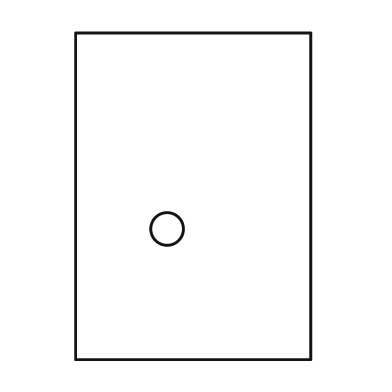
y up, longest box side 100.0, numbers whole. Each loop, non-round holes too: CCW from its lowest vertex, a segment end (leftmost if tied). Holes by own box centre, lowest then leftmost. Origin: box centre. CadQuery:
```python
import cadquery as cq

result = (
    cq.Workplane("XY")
    .moveTo(-36.0, -50.0)
    .lineTo(36.0, -50.0)
    .lineTo(36.0, 50.0)
    .lineTo(-36.0, 50.0)
    .close()
    .moveTo(-8.0, -10.0)
    .circle(5.0)
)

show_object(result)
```